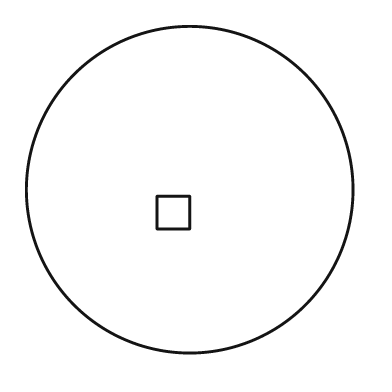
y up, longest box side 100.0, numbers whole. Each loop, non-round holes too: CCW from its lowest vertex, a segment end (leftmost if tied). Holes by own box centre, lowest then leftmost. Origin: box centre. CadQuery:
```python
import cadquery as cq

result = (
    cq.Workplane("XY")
    .moveTo(0.0, 0.0)
    .circle(50.0)
    .moveTo(-10.0, -12.0)
    .lineTo(0.0, -12.0)
    .lineTo(0.0, -2.0)
    .lineTo(-10.0, -2.0)
    .close()
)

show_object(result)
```